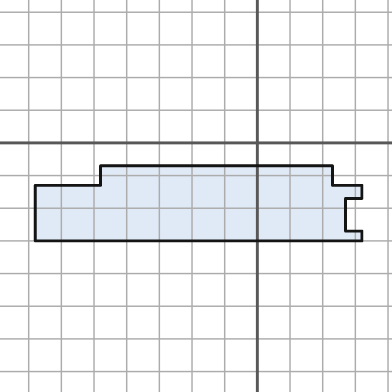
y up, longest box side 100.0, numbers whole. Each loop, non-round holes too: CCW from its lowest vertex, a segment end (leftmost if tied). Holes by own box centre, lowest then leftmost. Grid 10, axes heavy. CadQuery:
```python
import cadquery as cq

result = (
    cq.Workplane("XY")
    .moveTo(-68.0, -30.0)
    .lineTo(32.0, -30.0)
    .lineTo(32.0, -27.0)
    .lineTo(27.0, -27.0)
    .lineTo(27.0, -17.0)
    .lineTo(32.0, -17.0)
    .lineTo(32.0, -13.0)
    .lineTo(23.0, -13.0)
    .lineTo(23.0, -7.0)
    .lineTo(-48.0, -7.0)
    .lineTo(-48.0, -13.0)
    .lineTo(-68.0, -13.0)
    .close()
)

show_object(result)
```